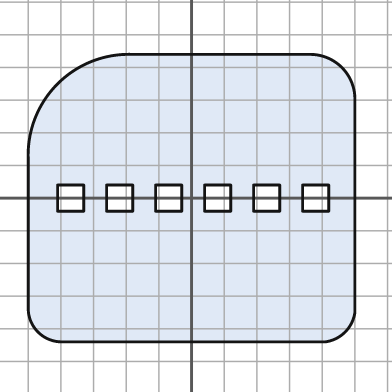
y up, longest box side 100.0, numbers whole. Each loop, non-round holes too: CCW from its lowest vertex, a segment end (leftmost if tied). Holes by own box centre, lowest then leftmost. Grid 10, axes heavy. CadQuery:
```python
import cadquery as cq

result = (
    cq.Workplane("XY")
    .moveTo(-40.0, -44.0)
    .lineTo(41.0, -44.0)
    .threePointArc((47.0, -41.0), (50.0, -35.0))
    .lineTo(50.0, 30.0)
    .threePointArc((46.0, 40.0), (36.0, 44.0))
    .lineTo(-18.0, 44.0)
    .threePointArc((-41.0, 35.0), (-50.0, 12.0))
    .lineTo(-50.0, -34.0)
    .threePointArc((-47.0, -41.0), (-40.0, -44.0))
    .close()
    .moveTo(-41.0, -4.0)
    .lineTo(-33.0, -4.0)
    .lineTo(-33.0, 4.0)
    .lineTo(-41.0, 4.0)
    .close()
    .moveTo(-26.0, -4.0)
    .lineTo(-18.0, -4.0)
    .lineTo(-18.0, 4.0)
    .lineTo(-26.0, 4.0)
    .close()
    .moveTo(-11.0, -4.0)
    .lineTo(-3.0, -4.0)
    .lineTo(-3.0, 4.0)
    .lineTo(-11.0, 4.0)
    .close()
    .moveTo(4.0, -4.0)
    .lineTo(12.0, -4.0)
    .lineTo(12.0, 4.0)
    .lineTo(4.0, 4.0)
    .close()
    .moveTo(19.0, -4.0)
    .lineTo(27.0, -4.0)
    .lineTo(27.0, 4.0)
    .lineTo(19.0, 4.0)
    .close()
    .moveTo(34.0, -4.0)
    .lineTo(42.0, -4.0)
    .lineTo(42.0, 4.0)
    .lineTo(34.0, 4.0)
    .close()
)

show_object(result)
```